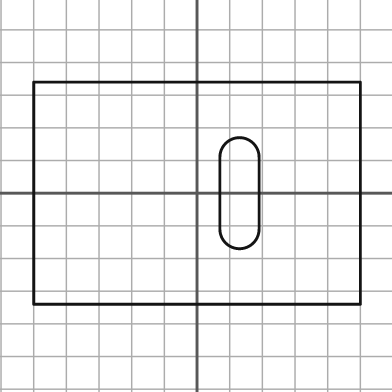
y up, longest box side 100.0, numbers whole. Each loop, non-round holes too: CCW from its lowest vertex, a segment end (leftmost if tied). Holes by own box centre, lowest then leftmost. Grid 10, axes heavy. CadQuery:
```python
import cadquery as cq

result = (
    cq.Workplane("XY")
    .moveTo(-50.0, -34.0)
    .lineTo(50.0, -34.0)
    .lineTo(50.0, 34.0)
    .lineTo(-50.0, 34.0)
    .close()
    .moveTo(7.0, -11.0)
    .threePointArc((13.0, -17.0), (19.0, -11.0))
    .lineTo(19.0, 11.0)
    .threePointArc((13.0, 17.0), (7.0, 11.0))
    .close()
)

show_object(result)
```